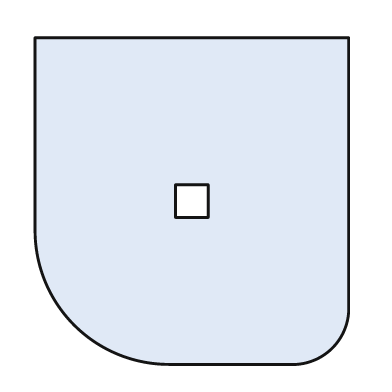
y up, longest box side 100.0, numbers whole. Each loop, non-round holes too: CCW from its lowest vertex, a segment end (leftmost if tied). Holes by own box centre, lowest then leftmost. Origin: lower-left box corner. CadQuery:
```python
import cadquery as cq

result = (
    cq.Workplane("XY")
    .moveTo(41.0, 0.0)
    .lineTo(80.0, 0.0)
    .threePointArc((91.0, 5.0), (96.0, 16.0))
    .lineTo(96.0, 100.0)
    .lineTo(0.0, 100.0)
    .lineTo(0.0, 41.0)
    .threePointArc((12.0, 12.0), (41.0, 0.0))
    .close()
    .moveTo(43.0, 45.0)
    .lineTo(53.0, 45.0)
    .lineTo(53.0, 55.0)
    .lineTo(43.0, 55.0)
    .close()
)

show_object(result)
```